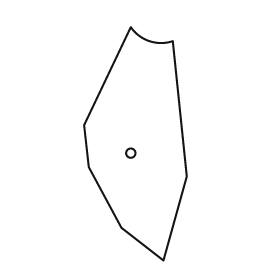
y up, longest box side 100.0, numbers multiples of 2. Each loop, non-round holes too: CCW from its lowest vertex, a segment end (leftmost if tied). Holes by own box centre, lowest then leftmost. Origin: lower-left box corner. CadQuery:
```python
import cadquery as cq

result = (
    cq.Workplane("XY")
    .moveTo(34.0, 0.0)
    .lineTo(44.0, 36.0)
    .lineTo(38.0, 94.0)
    .threePointArc((28.0, 94.0), (20.0, 100.0))
    .lineTo(0.0, 58.0)
    .lineTo(2.0, 40.0)
    .lineTo(16.0, 14.0)
    .close()
    .moveTo(20.0, 46.0)
    .circle(2.0)
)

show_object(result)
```